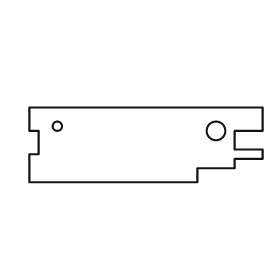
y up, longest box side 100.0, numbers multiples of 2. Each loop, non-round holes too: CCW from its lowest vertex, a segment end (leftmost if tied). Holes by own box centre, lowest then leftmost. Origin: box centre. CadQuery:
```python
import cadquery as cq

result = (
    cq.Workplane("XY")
    .moveTo(-50.0, -16.0)
    .lineTo(22.0, -16.0)
    .lineTo(22.0, -10.0)
    .lineTo(38.0, -10.0)
    .lineTo(38.0, -6.0)
    .lineTo(50.0, -6.0)
    .lineTo(50.0, -2.0)
    .lineTo(38.0, -2.0)
    .lineTo(38.0, 6.0)
    .lineTo(50.0, 6.0)
    .lineTo(50.0, 16.0)
    .lineTo(-50.0, 16.0)
    .lineTo(-50.0, 6.0)
    .lineTo(-46.0, 6.0)
    .lineTo(-46.0, -4.0)
    .lineTo(-50.0, -4.0)
    .close()
    .moveTo(30.0, 6.0)
    .circle(4.0)
    .moveTo(-38.0, 8.0)
    .circle(2.0)
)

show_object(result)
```